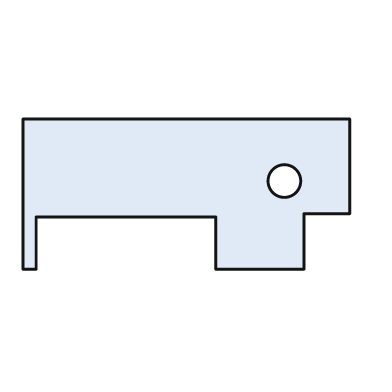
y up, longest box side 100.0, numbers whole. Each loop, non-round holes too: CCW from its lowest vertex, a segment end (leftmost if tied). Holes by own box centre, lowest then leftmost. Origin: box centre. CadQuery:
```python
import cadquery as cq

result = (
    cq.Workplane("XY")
    .moveTo(-50.0, -23.0)
    .lineTo(-46.0, -23.0)
    .lineTo(-46.0, -7.0)
    .lineTo(9.0, -7.0)
    .lineTo(9.0, -23.0)
    .lineTo(36.0, -23.0)
    .lineTo(36.0, -6.0)
    .lineTo(50.0, -6.0)
    .lineTo(50.0, 23.0)
    .lineTo(-50.0, 23.0)
    .close()
    .moveTo(30.0, 4.0)
    .circle(5.0)
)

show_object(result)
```